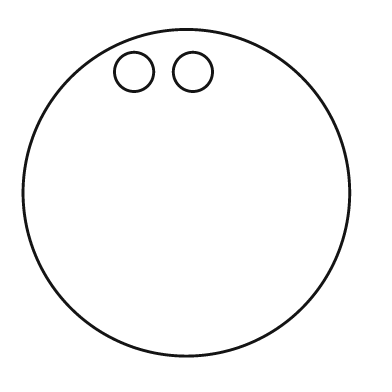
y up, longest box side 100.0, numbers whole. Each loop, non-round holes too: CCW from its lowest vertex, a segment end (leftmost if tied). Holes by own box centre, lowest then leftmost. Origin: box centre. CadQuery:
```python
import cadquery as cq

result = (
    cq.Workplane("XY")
    .moveTo(0.0, 0.0)
    .circle(50.0)
    .moveTo(-16.0, 37.0)
    .circle(6.0)
    .moveTo(2.0, 37.0)
    .circle(6.0)
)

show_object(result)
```